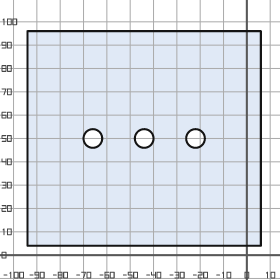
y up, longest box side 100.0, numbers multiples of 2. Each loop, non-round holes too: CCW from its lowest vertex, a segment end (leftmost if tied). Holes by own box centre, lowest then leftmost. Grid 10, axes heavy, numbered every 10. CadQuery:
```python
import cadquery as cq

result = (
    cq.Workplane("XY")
    .moveTo(-94.0, 4.0)
    .lineTo(6.0, 4.0)
    .lineTo(6.0, 96.0)
    .lineTo(-94.0, 96.0)
    .close()
    .moveTo(-66.0, 50.0)
    .circle(4.0)
    .moveTo(-44.0, 50.0)
    .circle(4.0)
    .moveTo(-22.0, 50.0)
    .circle(4.0)
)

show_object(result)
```